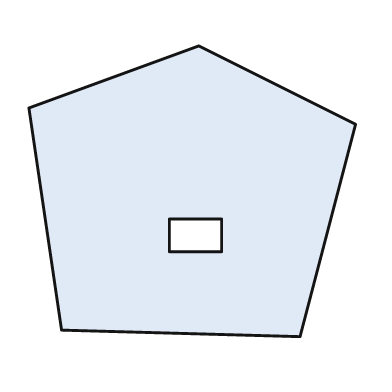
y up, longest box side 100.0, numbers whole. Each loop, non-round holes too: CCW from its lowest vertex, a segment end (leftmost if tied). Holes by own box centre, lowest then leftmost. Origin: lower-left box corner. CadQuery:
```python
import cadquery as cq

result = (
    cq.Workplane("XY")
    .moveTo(83.0, 0.0)
    .lineTo(100.0, 65.0)
    .lineTo(52.0, 89.0)
    .lineTo(0.0, 70.0)
    .lineTo(10.0, 2.0)
    .close()
    .moveTo(43.0, 26.0)
    .lineTo(59.0, 26.0)
    .lineTo(59.0, 36.0)
    .lineTo(43.0, 36.0)
    .close()
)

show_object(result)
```